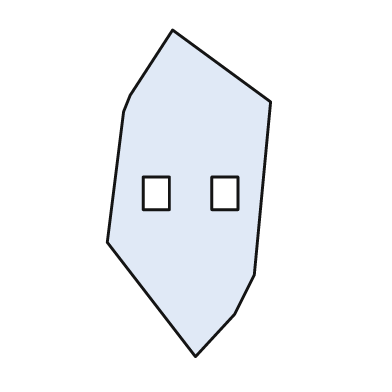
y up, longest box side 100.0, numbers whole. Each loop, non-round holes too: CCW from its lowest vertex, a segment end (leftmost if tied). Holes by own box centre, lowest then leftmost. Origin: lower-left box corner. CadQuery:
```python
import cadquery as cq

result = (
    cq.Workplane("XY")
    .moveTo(27.0, 0.0)
    .lineTo(39.0, 13.0)
    .lineTo(45.0, 25.0)
    .lineTo(50.0, 78.0)
    .lineTo(20.0, 100.0)
    .lineTo(7.0, 80.0)
    .lineTo(5.0, 75.0)
    .lineTo(0.0, 35.0)
    .close()
    .moveTo(11.0, 45.0)
    .lineTo(19.0, 45.0)
    .lineTo(19.0, 55.0)
    .lineTo(11.0, 55.0)
    .close()
    .moveTo(32.0, 45.0)
    .lineTo(40.0, 45.0)
    .lineTo(40.0, 55.0)
    .lineTo(32.0, 55.0)
    .close()
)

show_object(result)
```